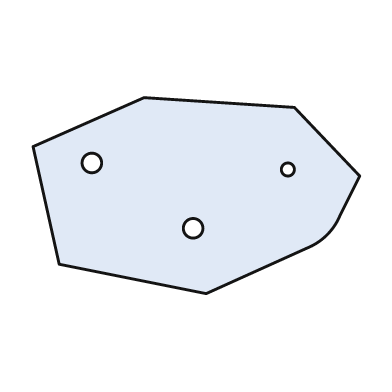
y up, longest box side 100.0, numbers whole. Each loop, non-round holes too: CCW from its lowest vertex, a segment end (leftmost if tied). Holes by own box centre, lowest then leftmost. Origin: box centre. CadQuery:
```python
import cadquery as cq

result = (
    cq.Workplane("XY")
    .moveTo(3.0, -30.0)
    .lineTo(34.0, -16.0)
    .threePointArc((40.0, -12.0), (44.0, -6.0))
    .lineTo(50.0, 6.0)
    .lineTo(30.0, 27.0)
    .lineTo(-16.0, 30.0)
    .lineTo(-50.0, 15.0)
    .lineTo(-42.0, -21.0)
    .close()
    .moveTo(-1.0, -10.0)
    .circle(3.0)
    .moveTo(28.0, 8.0)
    .circle(2.0)
    .moveTo(-32.0, 10.0)
    .circle(3.0)
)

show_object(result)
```